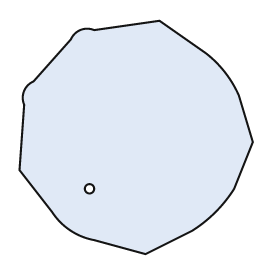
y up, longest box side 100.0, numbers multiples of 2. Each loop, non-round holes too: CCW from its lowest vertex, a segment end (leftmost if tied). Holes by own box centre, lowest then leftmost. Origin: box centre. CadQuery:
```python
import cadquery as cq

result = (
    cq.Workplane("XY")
    .moveTo(4.0, -50.0)
    .lineTo(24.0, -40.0)
    .threePointArc((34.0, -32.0), (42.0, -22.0))
    .lineTo(50.0, -2.0)
    .lineTo(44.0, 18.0)
    .threePointArc((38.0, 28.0), (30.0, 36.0))
    .lineTo(10.0, 50.0)
    .lineTo(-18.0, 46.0)
    .threePointArc((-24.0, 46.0), (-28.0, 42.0))
    .lineTo(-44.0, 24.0)
    .threePointArc((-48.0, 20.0), (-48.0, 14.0))
    .lineTo(-50.0, -14.0)
    .lineTo(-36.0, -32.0)
    .threePointArc((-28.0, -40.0), (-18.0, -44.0))
    .close()
    .moveTo(-20.0, -22.0)
    .circle(2.0)
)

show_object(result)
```